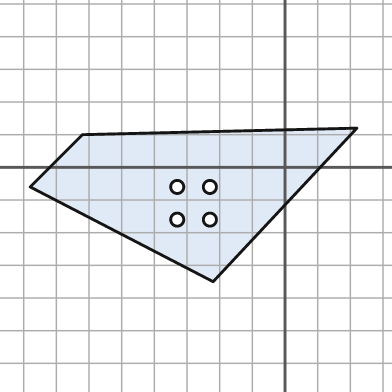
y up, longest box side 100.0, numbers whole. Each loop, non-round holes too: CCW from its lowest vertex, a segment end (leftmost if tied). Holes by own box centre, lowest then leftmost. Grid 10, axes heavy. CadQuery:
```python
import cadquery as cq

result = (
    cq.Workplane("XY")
    .moveTo(-22.0, -35.0)
    .lineTo(22.0, 12.0)
    .lineTo(-62.0, 10.0)
    .lineTo(-78.0, -6.0)
    .close()
    .moveTo(-33.0, -16.0)
    .circle(2.0)
    .moveTo(-23.0, -16.0)
    .circle(2.0)
    .moveTo(-33.0, -6.0)
    .circle(2.0)
    .moveTo(-23.0, -6.0)
    .circle(2.0)
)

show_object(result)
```